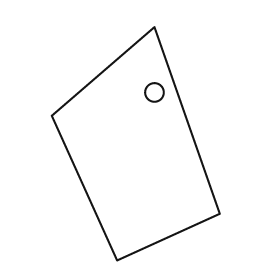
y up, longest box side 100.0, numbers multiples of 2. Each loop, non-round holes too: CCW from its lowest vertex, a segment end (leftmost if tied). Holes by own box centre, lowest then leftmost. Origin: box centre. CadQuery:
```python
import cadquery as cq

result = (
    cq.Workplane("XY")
    .moveTo(-8.0, -50.0)
    .lineTo(36.0, -30.0)
    .lineTo(8.0, 50.0)
    .lineTo(-36.0, 12.0)
    .close()
    .moveTo(8.0, 22.0)
    .circle(4.0)
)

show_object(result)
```